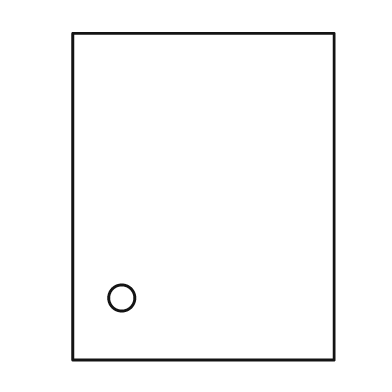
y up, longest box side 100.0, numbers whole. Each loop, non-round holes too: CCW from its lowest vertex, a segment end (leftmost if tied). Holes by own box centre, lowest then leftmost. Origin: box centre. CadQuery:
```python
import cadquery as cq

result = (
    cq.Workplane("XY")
    .moveTo(-40.0, -50.0)
    .lineTo(40.0, -50.0)
    .lineTo(40.0, 50.0)
    .lineTo(-40.0, 50.0)
    .close()
    .moveTo(-25.0, -31.0)
    .circle(4.0)
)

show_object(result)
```